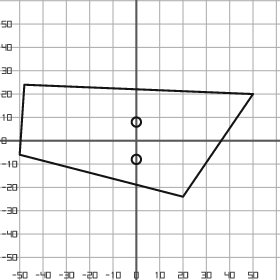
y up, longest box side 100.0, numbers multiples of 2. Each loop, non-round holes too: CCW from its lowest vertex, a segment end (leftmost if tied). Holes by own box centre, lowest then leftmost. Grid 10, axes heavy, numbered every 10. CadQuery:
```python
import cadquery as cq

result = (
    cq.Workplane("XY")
    .moveTo(20.0, -24.0)
    .lineTo(50.0, 20.0)
    .lineTo(-48.0, 24.0)
    .lineTo(-50.0, -6.0)
    .close()
    .moveTo(0.0, -8.0)
    .circle(2.0)
    .moveTo(0.0, 8.0)
    .circle(2.0)
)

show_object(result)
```